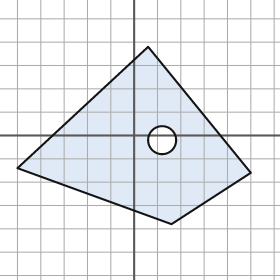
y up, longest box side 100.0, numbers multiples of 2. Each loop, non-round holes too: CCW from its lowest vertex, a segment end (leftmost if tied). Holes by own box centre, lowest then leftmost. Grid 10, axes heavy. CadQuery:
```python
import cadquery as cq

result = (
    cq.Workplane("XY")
    .moveTo(16.0, -38.0)
    .lineTo(50.0, -16.0)
    .lineTo(6.0, 38.0)
    .lineTo(-50.0, -14.0)
    .close()
    .moveTo(12.0, -2.0)
    .circle(6.0)
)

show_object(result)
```